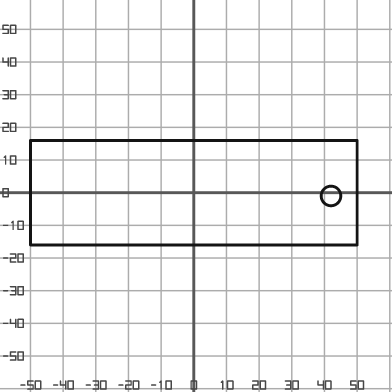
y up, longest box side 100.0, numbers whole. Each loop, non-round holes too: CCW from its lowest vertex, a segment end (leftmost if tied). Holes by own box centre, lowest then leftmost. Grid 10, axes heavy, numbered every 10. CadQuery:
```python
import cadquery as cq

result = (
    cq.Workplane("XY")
    .moveTo(-50.0, -16.0)
    .lineTo(50.0, -16.0)
    .lineTo(50.0, 16.0)
    .lineTo(-50.0, 16.0)
    .close()
    .moveTo(42.0, -1.0)
    .circle(3.0)
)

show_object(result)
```